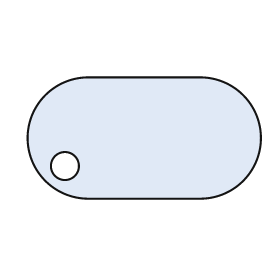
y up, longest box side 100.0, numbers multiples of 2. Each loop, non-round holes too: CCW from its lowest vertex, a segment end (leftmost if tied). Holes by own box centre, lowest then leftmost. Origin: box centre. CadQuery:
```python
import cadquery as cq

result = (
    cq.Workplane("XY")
    .moveTo(-24.0, -26.0)
    .lineTo(24.0, -26.0)
    .threePointArc((50.0, 0.0), (24.0, 26.0))
    .lineTo(-24.0, 26.0)
    .threePointArc((-50.0, 0.0), (-24.0, -26.0))
    .close()
    .moveTo(-34.0, -12.0)
    .circle(6.0)
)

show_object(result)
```